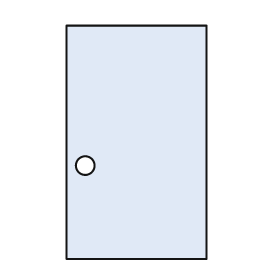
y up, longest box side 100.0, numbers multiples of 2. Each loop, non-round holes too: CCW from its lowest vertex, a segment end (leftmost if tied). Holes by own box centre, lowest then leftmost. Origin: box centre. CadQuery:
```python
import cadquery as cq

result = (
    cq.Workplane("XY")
    .moveTo(-30.0, -50.0)
    .lineTo(30.0, -50.0)
    .lineTo(30.0, 50.0)
    .lineTo(-30.0, 50.0)
    .close()
    .moveTo(-22.0, -10.0)
    .circle(4.0)
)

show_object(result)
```